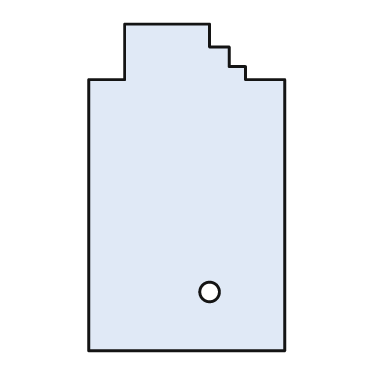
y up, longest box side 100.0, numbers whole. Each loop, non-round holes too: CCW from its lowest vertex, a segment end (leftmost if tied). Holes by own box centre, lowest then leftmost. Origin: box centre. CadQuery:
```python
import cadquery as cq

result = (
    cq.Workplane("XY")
    .moveTo(-30.0, -50.0)
    .lineTo(30.0, -50.0)
    .lineTo(30.0, 33.0)
    .lineTo(18.0, 33.0)
    .lineTo(18.0, 37.0)
    .lineTo(13.0, 37.0)
    .lineTo(13.0, 43.0)
    .lineTo(7.0, 43.0)
    .lineTo(7.0, 50.0)
    .lineTo(-19.0, 50.0)
    .lineTo(-19.0, 33.0)
    .lineTo(-30.0, 33.0)
    .close()
    .moveTo(7.0, -32.0)
    .circle(3.0)
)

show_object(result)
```